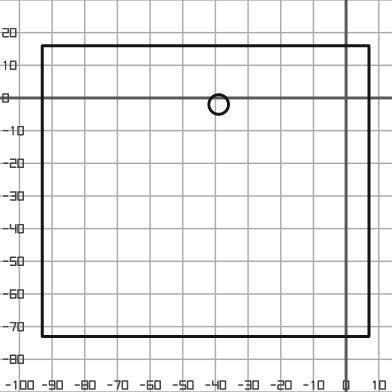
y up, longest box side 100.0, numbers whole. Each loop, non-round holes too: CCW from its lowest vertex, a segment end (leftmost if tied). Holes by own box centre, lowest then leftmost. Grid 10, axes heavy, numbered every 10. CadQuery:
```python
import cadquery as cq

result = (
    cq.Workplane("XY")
    .moveTo(-93.0, -73.0)
    .lineTo(7.0, -73.0)
    .lineTo(7.0, 16.0)
    .lineTo(-93.0, 16.0)
    .close()
    .moveTo(-39.0, -2.0)
    .circle(3.0)
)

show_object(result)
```